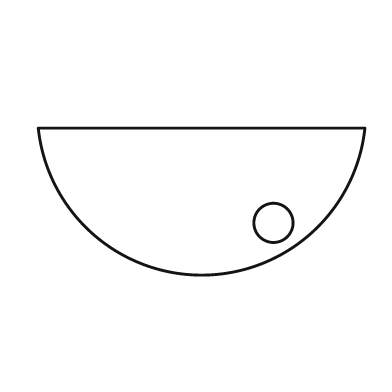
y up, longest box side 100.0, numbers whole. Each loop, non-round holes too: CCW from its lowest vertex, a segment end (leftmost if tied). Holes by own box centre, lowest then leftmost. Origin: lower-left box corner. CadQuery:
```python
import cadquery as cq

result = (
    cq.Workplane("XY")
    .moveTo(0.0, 45.0)
    .threePointArc((50.0, 0.0), (100.0, 45.0))
    .close()
    .moveTo(72.0, 16.0)
    .circle(6.0)
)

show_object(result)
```